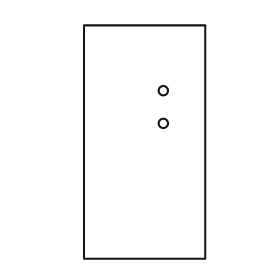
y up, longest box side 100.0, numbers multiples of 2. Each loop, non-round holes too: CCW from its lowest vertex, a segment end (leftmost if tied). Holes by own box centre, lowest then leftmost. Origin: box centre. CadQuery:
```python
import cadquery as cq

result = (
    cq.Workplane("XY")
    .moveTo(-26.0, -50.0)
    .lineTo(26.0, -50.0)
    .lineTo(26.0, 50.0)
    .lineTo(-26.0, 50.0)
    .close()
    .moveTo(8.0, 8.0)
    .circle(2.0)
    .moveTo(8.0, 22.0)
    .circle(2.0)
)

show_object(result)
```